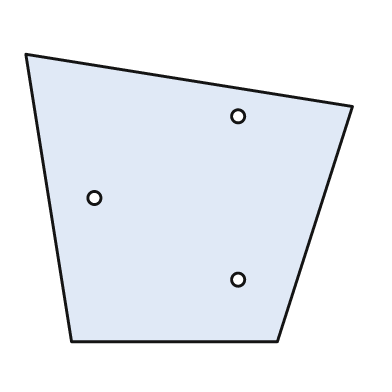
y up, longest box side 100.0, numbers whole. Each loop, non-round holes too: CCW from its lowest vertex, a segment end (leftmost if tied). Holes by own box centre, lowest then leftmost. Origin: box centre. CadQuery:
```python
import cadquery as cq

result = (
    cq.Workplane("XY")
    .moveTo(-36.0, -44.0)
    .lineTo(27.0, -44.0)
    .lineTo(50.0, 28.0)
    .lineTo(-50.0, 44.0)
    .close()
    .moveTo(15.0, -25.0)
    .circle(2.0)
    .moveTo(-29.0, 0.0)
    .circle(2.0)
    .moveTo(15.0, 25.0)
    .circle(2.0)
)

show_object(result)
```